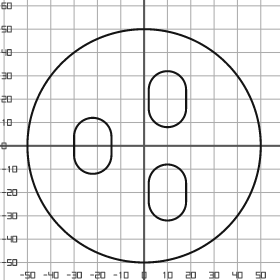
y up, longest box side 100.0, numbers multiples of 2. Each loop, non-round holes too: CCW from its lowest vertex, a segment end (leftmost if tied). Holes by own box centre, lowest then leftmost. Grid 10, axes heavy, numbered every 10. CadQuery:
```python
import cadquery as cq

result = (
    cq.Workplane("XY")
    .moveTo(0.0, 0.0)
    .circle(50.0)
    .moveTo(2.0, -24.0)
    .threePointArc((10.0, -32.0), (18.0, -24.0))
    .lineTo(18.0, -16.0)
    .threePointArc((10.0, -8.0), (2.0, -16.0))
    .close()
    .moveTo(-30.0, -4.0)
    .threePointArc((-22.0, -12.0), (-14.0, -4.0))
    .lineTo(-14.0, 4.0)
    .threePointArc((-22.0, 12.0), (-30.0, 4.0))
    .close()
    .moveTo(2.0, 16.0)
    .threePointArc((10.0, 8.0), (18.0, 16.0))
    .lineTo(18.0, 24.0)
    .threePointArc((10.0, 32.0), (2.0, 24.0))
    .close()
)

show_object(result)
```